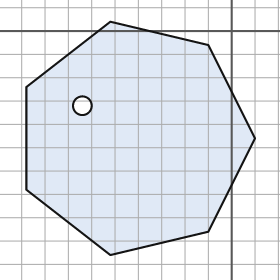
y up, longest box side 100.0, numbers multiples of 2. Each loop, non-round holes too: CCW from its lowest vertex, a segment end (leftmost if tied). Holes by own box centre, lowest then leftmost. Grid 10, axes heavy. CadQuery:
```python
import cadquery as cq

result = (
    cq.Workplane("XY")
    .moveTo(-52.0, -96.0)
    .lineTo(-10.0, -86.0)
    .lineTo(10.0, -46.0)
    .lineTo(-10.0, -6.0)
    .lineTo(-52.0, 4.0)
    .lineTo(-88.0, -24.0)
    .lineTo(-88.0, -68.0)
    .close()
    .moveTo(-64.0, -32.0)
    .circle(4.0)
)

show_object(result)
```